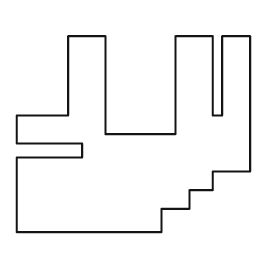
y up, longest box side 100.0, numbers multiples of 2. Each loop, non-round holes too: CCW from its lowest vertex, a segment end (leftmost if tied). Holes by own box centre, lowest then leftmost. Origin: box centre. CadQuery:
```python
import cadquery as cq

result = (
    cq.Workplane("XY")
    .moveTo(-50.0, -42.0)
    .lineTo(12.0, -42.0)
    .lineTo(12.0, -32.0)
    .lineTo(24.0, -32.0)
    .lineTo(24.0, -24.0)
    .lineTo(34.0, -24.0)
    .lineTo(34.0, -16.0)
    .lineTo(50.0, -16.0)
    .lineTo(50.0, 42.0)
    .lineTo(38.0, 42.0)
    .lineTo(38.0, 8.0)
    .lineTo(34.0, 8.0)
    .lineTo(34.0, 42.0)
    .lineTo(18.0, 42.0)
    .lineTo(18.0, 0.0)
    .lineTo(-12.0, 0.0)
    .lineTo(-12.0, 42.0)
    .lineTo(-28.0, 42.0)
    .lineTo(-28.0, 8.0)
    .lineTo(-50.0, 8.0)
    .lineTo(-50.0, -4.0)
    .lineTo(-22.0, -4.0)
    .lineTo(-22.0, -10.0)
    .lineTo(-50.0, -10.0)
    .close()
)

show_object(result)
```